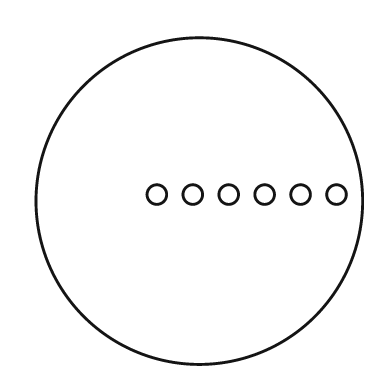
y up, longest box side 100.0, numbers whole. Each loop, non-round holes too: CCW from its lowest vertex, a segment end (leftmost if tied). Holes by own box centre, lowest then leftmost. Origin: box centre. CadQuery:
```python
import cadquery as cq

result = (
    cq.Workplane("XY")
    .moveTo(0.0, 0.0)
    .circle(50.0)
    .moveTo(-13.0, 2.0)
    .circle(3.0)
    .moveTo(-2.0, 2.0)
    .circle(3.0)
    .moveTo(9.0, 2.0)
    .circle(3.0)
    .moveTo(20.0, 2.0)
    .circle(3.0)
    .moveTo(31.0, 2.0)
    .circle(3.0)
    .moveTo(42.0, 2.0)
    .circle(3.0)
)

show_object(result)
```